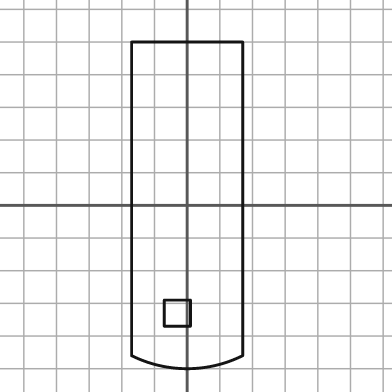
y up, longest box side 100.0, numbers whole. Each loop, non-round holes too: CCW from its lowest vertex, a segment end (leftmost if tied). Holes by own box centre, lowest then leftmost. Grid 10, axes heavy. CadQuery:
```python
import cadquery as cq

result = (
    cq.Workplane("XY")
    .moveTo(-17.0, -46.0)
    .threePointArc((0.0, -50.0), (17.0, -46.0))
    .lineTo(17.0, 50.0)
    .lineTo(-17.0, 50.0)
    .close()
    .moveTo(-7.0, -37.0)
    .lineTo(1.0, -37.0)
    .lineTo(1.0, -29.0)
    .lineTo(-7.0, -29.0)
    .close()
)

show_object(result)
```